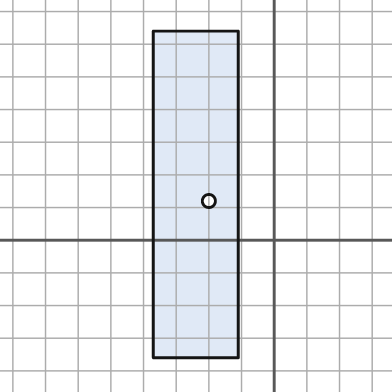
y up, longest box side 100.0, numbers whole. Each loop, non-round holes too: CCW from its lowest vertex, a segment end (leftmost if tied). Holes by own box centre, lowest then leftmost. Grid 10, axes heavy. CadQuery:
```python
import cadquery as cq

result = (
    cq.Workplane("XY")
    .moveTo(-37.0, -36.0)
    .lineTo(-11.0, -36.0)
    .lineTo(-11.0, 64.0)
    .lineTo(-37.0, 64.0)
    .close()
    .moveTo(-20.0, 12.0)
    .circle(2.0)
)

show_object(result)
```